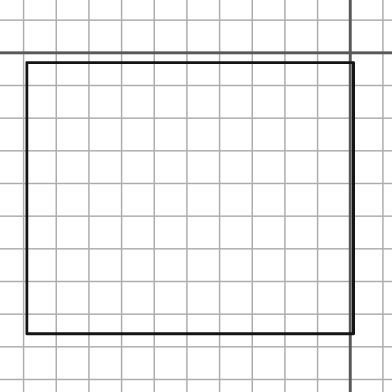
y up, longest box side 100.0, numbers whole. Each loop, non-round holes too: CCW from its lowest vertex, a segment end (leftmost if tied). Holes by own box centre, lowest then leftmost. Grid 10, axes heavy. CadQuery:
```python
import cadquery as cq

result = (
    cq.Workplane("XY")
    .moveTo(-99.0, -86.0)
    .lineTo(1.0, -86.0)
    .lineTo(1.0, -3.0)
    .lineTo(-99.0, -3.0)
    .close()
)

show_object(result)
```